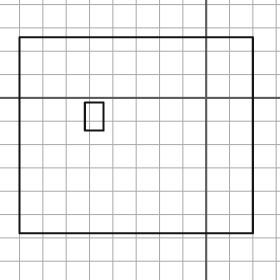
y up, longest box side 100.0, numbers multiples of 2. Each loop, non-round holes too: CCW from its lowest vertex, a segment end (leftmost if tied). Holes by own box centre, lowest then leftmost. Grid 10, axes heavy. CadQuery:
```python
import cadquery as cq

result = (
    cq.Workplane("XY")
    .moveTo(-80.0, -58.0)
    .lineTo(20.0, -58.0)
    .lineTo(20.0, 26.0)
    .lineTo(-80.0, 26.0)
    .close()
    .moveTo(-52.0, -14.0)
    .lineTo(-44.0, -14.0)
    .lineTo(-44.0, -2.0)
    .lineTo(-52.0, -2.0)
    .close()
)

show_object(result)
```